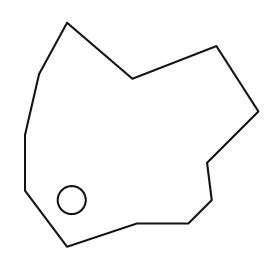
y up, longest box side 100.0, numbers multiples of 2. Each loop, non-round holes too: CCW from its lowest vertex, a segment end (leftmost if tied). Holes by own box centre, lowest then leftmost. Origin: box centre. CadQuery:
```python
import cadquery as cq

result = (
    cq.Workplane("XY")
    .moveTo(-32.0, -48.0)
    .lineTo(-2.0, -38.0)
    .lineTo(20.0, -38.0)
    .lineTo(30.0, -28.0)
    .lineTo(28.0, -12.0)
    .lineTo(50.0, 10.0)
    .lineTo(32.0, 38.0)
    .lineTo(-4.0, 24.0)
    .lineTo(-32.0, 48.0)
    .lineTo(-44.0, 26.0)
    .lineTo(-50.0, 0.0)
    .lineTo(-50.0, -24.0)
    .close()
    .moveTo(-30.0, -28.0)
    .circle(6.0)
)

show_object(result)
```